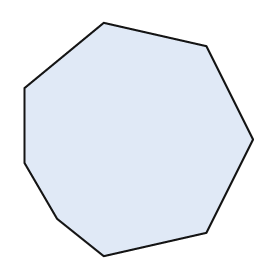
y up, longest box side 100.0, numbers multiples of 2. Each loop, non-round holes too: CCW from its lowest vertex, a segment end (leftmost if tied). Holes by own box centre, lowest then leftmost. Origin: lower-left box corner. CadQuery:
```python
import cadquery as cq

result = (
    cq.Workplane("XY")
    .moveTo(34.0, 0.0)
    .lineTo(78.0, 10.0)
    .lineTo(98.0, 50.0)
    .lineTo(78.0, 90.0)
    .lineTo(34.0, 100.0)
    .lineTo(0.0, 72.0)
    .lineTo(0.0, 40.0)
    .lineTo(14.0, 16.0)
    .close()
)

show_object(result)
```